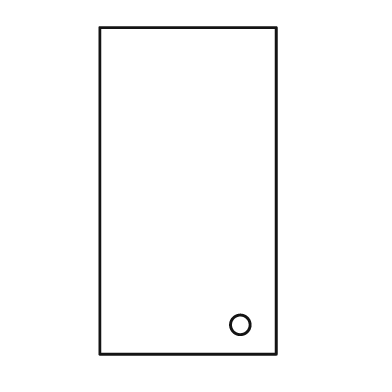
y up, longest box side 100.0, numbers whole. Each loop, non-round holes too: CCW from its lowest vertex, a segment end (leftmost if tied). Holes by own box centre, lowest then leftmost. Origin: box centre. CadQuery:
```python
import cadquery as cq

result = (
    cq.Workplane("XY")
    .moveTo(-27.0, -50.0)
    .lineTo(27.0, -50.0)
    .lineTo(27.0, 50.0)
    .lineTo(-27.0, 50.0)
    .close()
    .moveTo(16.0, -41.0)
    .circle(3.0)
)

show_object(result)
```